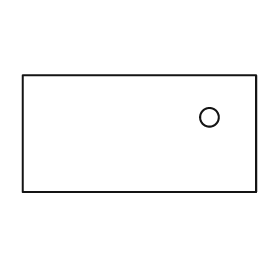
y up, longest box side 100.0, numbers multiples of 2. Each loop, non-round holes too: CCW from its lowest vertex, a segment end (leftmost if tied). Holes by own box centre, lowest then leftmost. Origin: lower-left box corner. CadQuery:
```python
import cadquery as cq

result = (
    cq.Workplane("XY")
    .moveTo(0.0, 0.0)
    .lineTo(100.0, 0.0)
    .lineTo(100.0, 50.0)
    .lineTo(0.0, 50.0)
    .close()
    .moveTo(80.0, 32.0)
    .circle(4.0)
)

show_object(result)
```